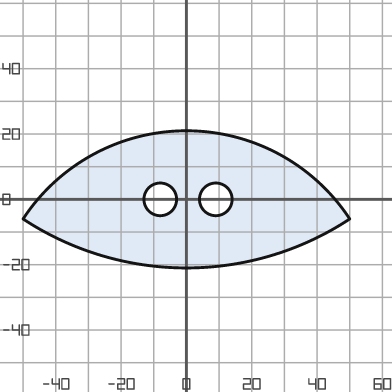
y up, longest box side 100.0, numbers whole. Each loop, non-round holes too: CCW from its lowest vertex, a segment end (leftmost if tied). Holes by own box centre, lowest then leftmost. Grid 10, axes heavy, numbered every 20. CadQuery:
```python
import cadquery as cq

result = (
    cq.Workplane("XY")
    .moveTo(-50.0, -6.0)
    .threePointArc((0.0, -21.0), (50.0, -6.0))
    .threePointArc((0.0, 21.0), (-50.0, -6.0))
    .close()
    .moveTo(-8.0, 0.0)
    .circle(5.0)
    .moveTo(9.0, 0.0)
    .circle(5.0)
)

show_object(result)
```